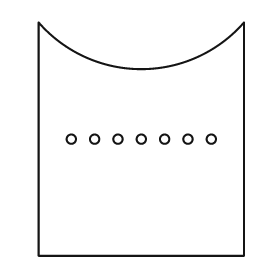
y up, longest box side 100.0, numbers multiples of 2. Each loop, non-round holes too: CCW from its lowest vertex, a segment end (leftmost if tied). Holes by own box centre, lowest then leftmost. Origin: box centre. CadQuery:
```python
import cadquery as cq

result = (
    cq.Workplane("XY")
    .moveTo(-44.0, -50.0)
    .lineTo(44.0, -50.0)
    .lineTo(44.0, 50.0)
    .threePointArc((0.0, 30.0), (-44.0, 50.0))
    .close()
    .moveTo(-30.0, 0.0)
    .circle(2.0)
    .moveTo(-20.0, 0.0)
    .circle(2.0)
    .moveTo(-10.0, 0.0)
    .circle(2.0)
    .moveTo(0.0, 0.0)
    .circle(2.0)
    .moveTo(10.0, 0.0)
    .circle(2.0)
    .moveTo(20.0, 0.0)
    .circle(2.0)
    .moveTo(30.0, 0.0)
    .circle(2.0)
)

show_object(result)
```